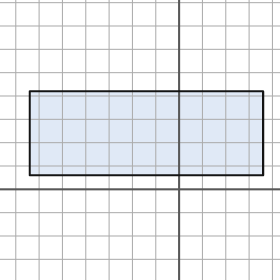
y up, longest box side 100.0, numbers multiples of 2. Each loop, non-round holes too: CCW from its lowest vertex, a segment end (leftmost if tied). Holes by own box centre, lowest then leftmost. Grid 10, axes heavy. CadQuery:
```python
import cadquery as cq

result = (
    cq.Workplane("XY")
    .moveTo(-64.0, 6.0)
    .lineTo(36.0, 6.0)
    .lineTo(36.0, 42.0)
    .lineTo(-64.0, 42.0)
    .close()
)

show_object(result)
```